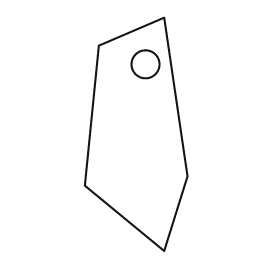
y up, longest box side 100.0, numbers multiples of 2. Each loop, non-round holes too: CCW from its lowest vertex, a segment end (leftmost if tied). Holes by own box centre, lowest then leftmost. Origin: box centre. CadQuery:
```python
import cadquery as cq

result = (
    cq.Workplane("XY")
    .moveTo(12.0, -50.0)
    .lineTo(22.0, -18.0)
    .lineTo(12.0, 50.0)
    .lineTo(-16.0, 38.0)
    .lineTo(-22.0, -22.0)
    .close()
    .moveTo(4.0, 30.0)
    .circle(6.0)
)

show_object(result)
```